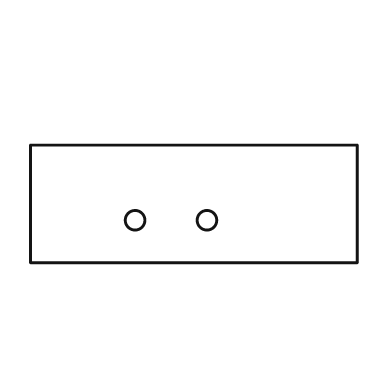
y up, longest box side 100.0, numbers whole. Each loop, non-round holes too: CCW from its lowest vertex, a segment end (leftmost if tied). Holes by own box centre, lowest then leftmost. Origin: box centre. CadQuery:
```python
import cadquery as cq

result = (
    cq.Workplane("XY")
    .moveTo(-50.0, -18.0)
    .lineTo(50.0, -18.0)
    .lineTo(50.0, 18.0)
    .lineTo(-50.0, 18.0)
    .close()
    .moveTo(-18.0, -5.0)
    .circle(3.0)
    .moveTo(4.0, -5.0)
    .circle(3.0)
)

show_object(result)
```